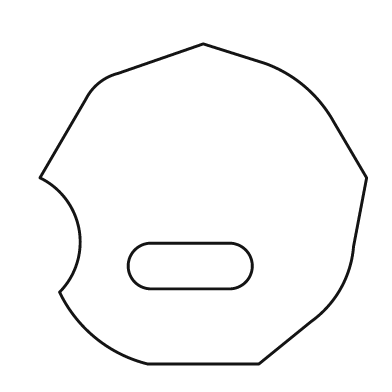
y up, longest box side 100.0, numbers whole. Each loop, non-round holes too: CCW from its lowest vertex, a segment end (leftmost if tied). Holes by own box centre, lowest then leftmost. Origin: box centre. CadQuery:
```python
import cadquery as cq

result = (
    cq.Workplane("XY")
    .moveTo(-17.0, -49.0)
    .lineTo(17.0, -49.0)
    .lineTo(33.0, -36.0)
    .threePointArc((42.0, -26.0), (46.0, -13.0))
    .lineTo(50.0, 8.0)
    .lineTo(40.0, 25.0)
    .threePointArc((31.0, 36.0), (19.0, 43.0))
    .lineTo(0.0, 49.0)
    .lineTo(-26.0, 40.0)
    .threePointArc((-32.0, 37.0), (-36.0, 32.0))
    .lineTo(-50.0, 8.0)
    .threePointArc((-38.0, -8.0), (-44.0, -27.0))
    .threePointArc((-33.0, -41.0), (-17.0, -49.0))
    .close()
    .moveTo(-16.0, -26.0)
    .lineTo(8.0, -26.0)
    .threePointArc((15.0, -19.0), (8.0, -12.0))
    .lineTo(-16.0, -12.0)
    .threePointArc((-23.0, -19.0), (-16.0, -26.0))
    .close()
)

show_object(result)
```